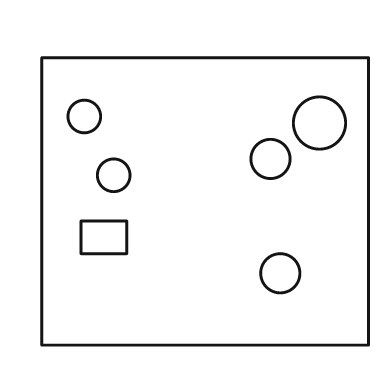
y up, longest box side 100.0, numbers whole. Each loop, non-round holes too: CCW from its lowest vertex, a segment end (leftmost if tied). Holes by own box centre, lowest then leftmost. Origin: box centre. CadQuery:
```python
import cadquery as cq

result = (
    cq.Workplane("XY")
    .moveTo(-50.0, -44.0)
    .lineTo(50.0, -44.0)
    .lineTo(50.0, 44.0)
    .lineTo(-50.0, 44.0)
    .close()
    .moveTo(23.0, -22.0)
    .circle(6.0)
    .moveTo(-38.0, -16.0)
    .lineTo(-24.0, -16.0)
    .lineTo(-24.0, -6.0)
    .lineTo(-38.0, -6.0)
    .close()
    .moveTo(-28.0, 8.0)
    .circle(5.0)
    .moveTo(20.0, 13.0)
    .circle(6.0)
    .moveTo(35.0, 24.0)
    .circle(8.0)
    .moveTo(-37.0, 26.0)
    .circle(5.0)
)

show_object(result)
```